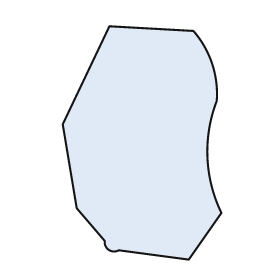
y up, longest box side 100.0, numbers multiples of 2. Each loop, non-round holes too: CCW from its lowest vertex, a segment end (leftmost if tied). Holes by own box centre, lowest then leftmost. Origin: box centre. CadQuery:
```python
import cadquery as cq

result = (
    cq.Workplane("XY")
    .moveTo(20.0, -50.0)
    .lineTo(34.0, -30.0)
    .threePointArc((28.0, -6.0), (32.0, 18.0))
    .threePointArc((30.0, 34.0), (22.0, 48.0))
    .lineTo(-14.0, 50.0)
    .lineTo(-34.0, 8.0)
    .lineTo(-28.0, -28.0)
    .lineTo(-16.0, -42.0)
    .threePointArc((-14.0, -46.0), (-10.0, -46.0))
    .close()
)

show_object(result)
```